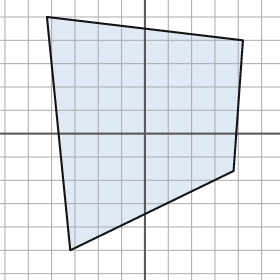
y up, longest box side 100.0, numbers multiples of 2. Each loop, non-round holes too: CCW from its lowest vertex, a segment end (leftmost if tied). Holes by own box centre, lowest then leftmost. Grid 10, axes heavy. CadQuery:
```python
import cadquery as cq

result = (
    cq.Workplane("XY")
    .moveTo(-32.0, -50.0)
    .lineTo(38.0, -16.0)
    .lineTo(42.0, 40.0)
    .lineTo(-42.0, 50.0)
    .close()
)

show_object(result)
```